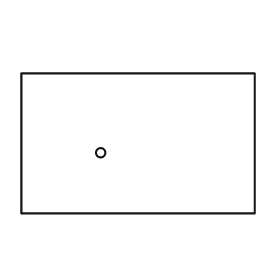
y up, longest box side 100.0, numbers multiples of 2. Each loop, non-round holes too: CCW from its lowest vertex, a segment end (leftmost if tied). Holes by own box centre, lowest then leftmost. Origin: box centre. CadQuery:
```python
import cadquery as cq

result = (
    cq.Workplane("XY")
    .moveTo(-50.0, -30.0)
    .lineTo(50.0, -30.0)
    .lineTo(50.0, 30.0)
    .lineTo(-50.0, 30.0)
    .close()
    .moveTo(-16.0, -4.0)
    .circle(2.0)
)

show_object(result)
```